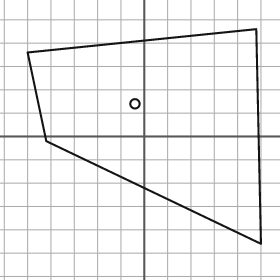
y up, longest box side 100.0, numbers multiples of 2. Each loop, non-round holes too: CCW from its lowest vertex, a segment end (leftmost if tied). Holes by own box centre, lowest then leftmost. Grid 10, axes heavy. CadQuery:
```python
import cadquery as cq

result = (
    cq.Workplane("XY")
    .moveTo(50.0, -46.0)
    .lineTo(48.0, 46.0)
    .lineTo(-50.0, 36.0)
    .lineTo(-42.0, -2.0)
    .close()
    .moveTo(-4.0, 14.0)
    .circle(2.0)
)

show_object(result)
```